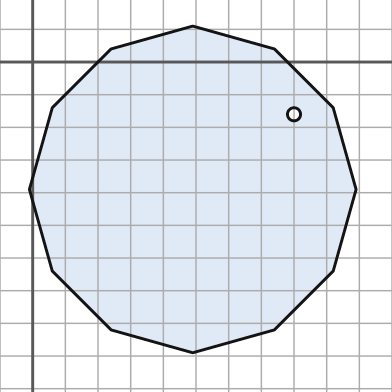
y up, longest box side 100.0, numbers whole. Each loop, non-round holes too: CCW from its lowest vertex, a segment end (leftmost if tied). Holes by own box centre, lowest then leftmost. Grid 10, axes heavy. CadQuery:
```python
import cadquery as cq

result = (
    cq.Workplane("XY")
    .moveTo(49.0, -89.0)
    .lineTo(74.0, -82.0)
    .lineTo(92.0, -64.0)
    .lineTo(99.0, -39.0)
    .lineTo(92.0, -14.0)
    .lineTo(74.0, 4.0)
    .lineTo(49.0, 11.0)
    .lineTo(24.0, 4.0)
    .lineTo(6.0, -14.0)
    .lineTo(-1.0, -39.0)
    .lineTo(6.0, -64.0)
    .lineTo(24.0, -82.0)
    .close()
    .moveTo(80.0, -16.0)
    .circle(2.0)
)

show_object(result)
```